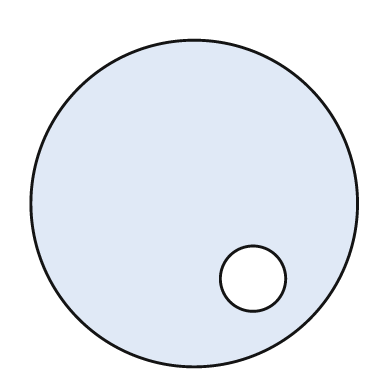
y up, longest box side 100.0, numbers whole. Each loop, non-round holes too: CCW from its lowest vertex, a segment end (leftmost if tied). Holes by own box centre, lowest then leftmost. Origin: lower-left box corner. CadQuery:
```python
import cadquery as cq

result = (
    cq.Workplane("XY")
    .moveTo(50.0, 50.0)
    .circle(50.0)
    .moveTo(68.0, 27.0)
    .circle(10.0)
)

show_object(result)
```